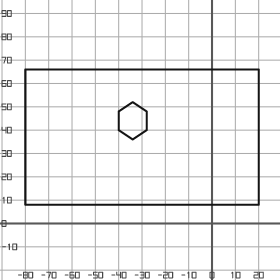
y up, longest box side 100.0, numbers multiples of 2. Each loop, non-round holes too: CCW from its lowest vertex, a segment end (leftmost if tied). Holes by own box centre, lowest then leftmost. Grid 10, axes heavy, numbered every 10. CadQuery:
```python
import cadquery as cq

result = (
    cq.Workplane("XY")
    .moveTo(-80.0, 8.0)
    .lineTo(20.0, 8.0)
    .lineTo(20.0, 66.0)
    .lineTo(-80.0, 66.0)
    .close()
    .moveTo(-34.0, 36.0)
    .lineTo(-28.0, 40.0)
    .lineTo(-28.0, 48.0)
    .lineTo(-34.0, 52.0)
    .lineTo(-40.0, 48.0)
    .lineTo(-40.0, 40.0)
    .close()
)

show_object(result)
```